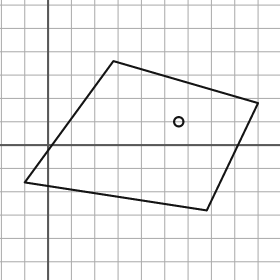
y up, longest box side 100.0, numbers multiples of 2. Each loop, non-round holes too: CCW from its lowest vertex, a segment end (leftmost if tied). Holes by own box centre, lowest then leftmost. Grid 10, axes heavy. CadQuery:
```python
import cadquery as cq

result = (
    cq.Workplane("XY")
    .moveTo(68.0, -28.0)
    .lineTo(90.0, 18.0)
    .lineTo(28.0, 36.0)
    .lineTo(-10.0, -16.0)
    .close()
    .moveTo(56.0, 10.0)
    .circle(2.0)
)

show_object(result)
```